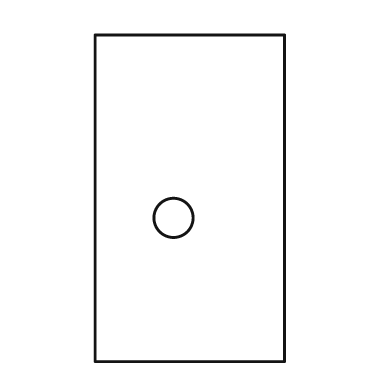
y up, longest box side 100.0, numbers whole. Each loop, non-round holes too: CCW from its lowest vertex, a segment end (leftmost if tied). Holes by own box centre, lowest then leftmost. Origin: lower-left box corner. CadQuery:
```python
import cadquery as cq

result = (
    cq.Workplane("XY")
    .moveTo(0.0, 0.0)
    .lineTo(58.0, 0.0)
    .lineTo(58.0, 100.0)
    .lineTo(0.0, 100.0)
    .close()
    .moveTo(24.0, 44.0)
    .circle(6.0)
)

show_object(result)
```